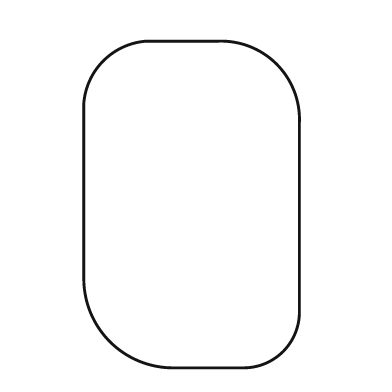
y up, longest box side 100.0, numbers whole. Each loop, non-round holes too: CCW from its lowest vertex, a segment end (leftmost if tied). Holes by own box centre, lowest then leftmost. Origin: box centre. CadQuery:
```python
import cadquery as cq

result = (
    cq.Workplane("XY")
    .moveTo(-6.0, -50.0)
    .lineTo(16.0, -50.0)
    .threePointArc((28.0, -45.0), (33.0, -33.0))
    .lineTo(33.0, 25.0)
    .threePointArc((26.0, 43.0), (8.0, 50.0))
    .lineTo(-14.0, 50.0)
    .threePointArc((-27.0, 44.0), (-33.0, 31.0))
    .lineTo(-33.0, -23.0)
    .threePointArc((-25.0, -42.0), (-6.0, -50.0))
    .close()
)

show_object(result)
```